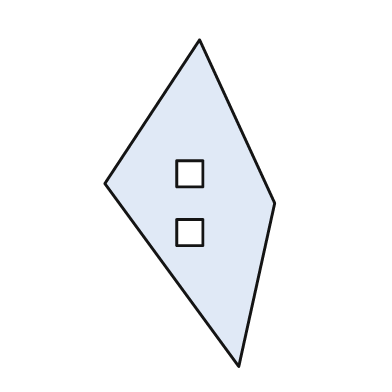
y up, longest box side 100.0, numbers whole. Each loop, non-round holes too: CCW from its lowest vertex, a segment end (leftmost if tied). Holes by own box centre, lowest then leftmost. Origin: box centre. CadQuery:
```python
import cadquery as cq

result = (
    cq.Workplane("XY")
    .moveTo(15.0, -50.0)
    .lineTo(26.0, 0.0)
    .lineTo(3.0, 50.0)
    .lineTo(-26.0, 6.0)
    .close()
    .moveTo(-4.0, -13.0)
    .lineTo(4.0, -13.0)
    .lineTo(4.0, -5.0)
    .lineTo(-4.0, -5.0)
    .close()
    .moveTo(-4.0, 5.0)
    .lineTo(4.0, 5.0)
    .lineTo(4.0, 13.0)
    .lineTo(-4.0, 13.0)
    .close()
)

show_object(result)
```